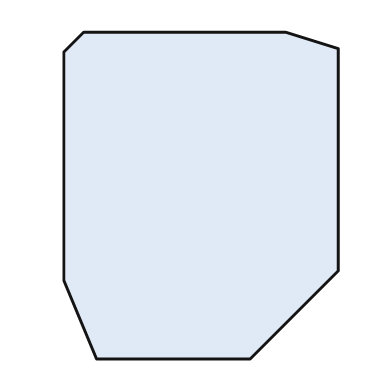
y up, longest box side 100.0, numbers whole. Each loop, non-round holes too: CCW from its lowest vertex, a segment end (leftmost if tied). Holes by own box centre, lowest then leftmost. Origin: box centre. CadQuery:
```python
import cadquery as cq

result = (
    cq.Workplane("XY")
    .moveTo(-32.0, -50.0)
    .lineTo(15.0, -50.0)
    .lineTo(42.0, -23.0)
    .lineTo(42.0, 45.0)
    .lineTo(26.0, 50.0)
    .lineTo(-36.0, 50.0)
    .lineTo(-42.0, 44.0)
    .lineTo(-42.0, -26.0)
    .close()
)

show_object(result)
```